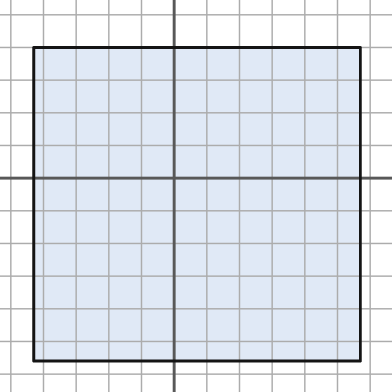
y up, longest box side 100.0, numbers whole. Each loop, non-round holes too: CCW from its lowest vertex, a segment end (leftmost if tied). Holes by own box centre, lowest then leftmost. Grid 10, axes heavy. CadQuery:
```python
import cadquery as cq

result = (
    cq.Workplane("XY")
    .moveTo(-43.0, -56.0)
    .lineTo(57.0, -56.0)
    .lineTo(57.0, 40.0)
    .lineTo(-43.0, 40.0)
    .close()
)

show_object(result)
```